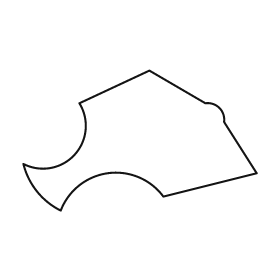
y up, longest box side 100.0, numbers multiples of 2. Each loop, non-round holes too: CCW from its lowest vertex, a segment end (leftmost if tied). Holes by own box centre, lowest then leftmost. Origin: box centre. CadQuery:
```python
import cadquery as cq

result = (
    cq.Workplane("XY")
    .moveTo(-34.0, -30.0)
    .threePointArc((-14.0, -14.0), (10.0, -24.0))
    .lineTo(50.0, -14.0)
    .lineTo(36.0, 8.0)
    .threePointArc((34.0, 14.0), (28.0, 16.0))
    .lineTo(4.0, 30.0)
    .lineTo(-26.0, 16.0)
    .threePointArc((-28.0, -6.0), (-50.0, -10.0))
    .threePointArc((-44.0, -22.0), (-34.0, -30.0))
    .close()
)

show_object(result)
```